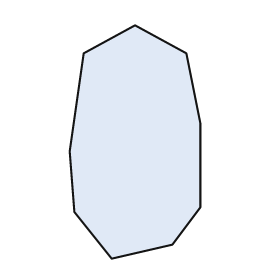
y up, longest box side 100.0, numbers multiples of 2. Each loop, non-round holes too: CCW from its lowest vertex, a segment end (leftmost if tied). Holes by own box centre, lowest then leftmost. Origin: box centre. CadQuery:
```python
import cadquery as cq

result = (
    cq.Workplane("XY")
    .moveTo(-10.0, -50.0)
    .lineTo(16.0, -44.0)
    .lineTo(28.0, -28.0)
    .lineTo(28.0, 8.0)
    .lineTo(22.0, 38.0)
    .lineTo(0.0, 50.0)
    .lineTo(-22.0, 38.0)
    .lineTo(-28.0, -4.0)
    .lineTo(-26.0, -30.0)
    .close()
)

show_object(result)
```